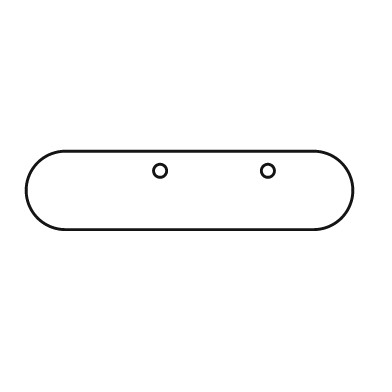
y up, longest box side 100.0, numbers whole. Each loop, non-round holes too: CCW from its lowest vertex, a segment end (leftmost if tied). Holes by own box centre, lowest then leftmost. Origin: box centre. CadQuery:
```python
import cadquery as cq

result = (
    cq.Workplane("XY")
    .moveTo(-38.0, -12.0)
    .lineTo(38.0, -12.0)
    .threePointArc((50.0, 0.0), (38.0, 12.0))
    .lineTo(-38.0, 12.0)
    .threePointArc((-50.0, 0.0), (-38.0, -12.0))
    .close()
    .moveTo(-9.0, 6.0)
    .circle(2.0)
    .moveTo(24.0, 6.0)
    .circle(2.0)
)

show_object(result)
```